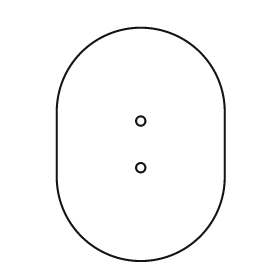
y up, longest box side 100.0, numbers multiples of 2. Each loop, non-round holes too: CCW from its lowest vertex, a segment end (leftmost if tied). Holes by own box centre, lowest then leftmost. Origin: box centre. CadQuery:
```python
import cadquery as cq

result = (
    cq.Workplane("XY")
    .moveTo(-36.0, -14.0)
    .threePointArc((0.0, -50.0), (36.0, -14.0))
    .lineTo(36.0, 14.0)
    .threePointArc((0.0, 50.0), (-36.0, 14.0))
    .close()
    .moveTo(0.0, -10.0)
    .circle(2.0)
    .moveTo(0.0, 10.0)
    .circle(2.0)
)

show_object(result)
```